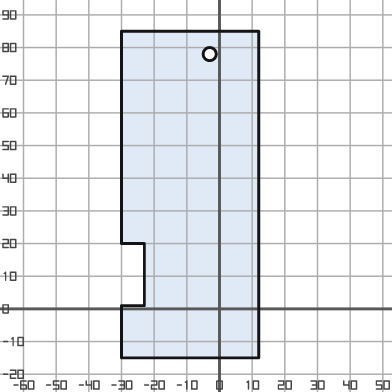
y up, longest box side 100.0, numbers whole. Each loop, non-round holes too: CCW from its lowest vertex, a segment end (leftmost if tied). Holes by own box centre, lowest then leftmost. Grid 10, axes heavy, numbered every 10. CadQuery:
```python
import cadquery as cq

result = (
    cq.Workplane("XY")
    .moveTo(-30.0, -15.0)
    .lineTo(12.0, -15.0)
    .lineTo(12.0, 85.0)
    .lineTo(-30.0, 85.0)
    .lineTo(-30.0, 20.0)
    .lineTo(-23.0, 20.0)
    .lineTo(-23.0, 1.0)
    .lineTo(-30.0, 1.0)
    .close()
    .moveTo(-3.0, 78.0)
    .circle(2.0)
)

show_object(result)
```